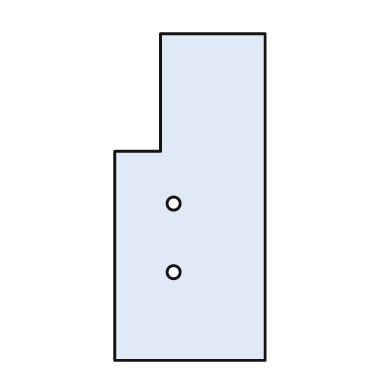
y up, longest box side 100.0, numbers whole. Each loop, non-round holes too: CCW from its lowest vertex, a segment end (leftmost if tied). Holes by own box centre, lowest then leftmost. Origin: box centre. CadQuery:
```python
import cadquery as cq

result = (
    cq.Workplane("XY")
    .moveTo(-23.0, -50.0)
    .lineTo(23.0, -50.0)
    .lineTo(23.0, 50.0)
    .lineTo(-9.0, 50.0)
    .lineTo(-9.0, 14.0)
    .lineTo(-23.0, 14.0)
    .close()
    .moveTo(-5.0, -23.0)
    .circle(2.0)
    .moveTo(-5.0, -2.0)
    .circle(2.0)
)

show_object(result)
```